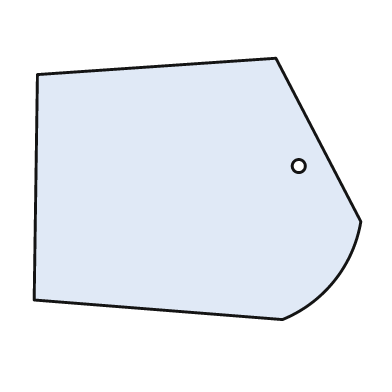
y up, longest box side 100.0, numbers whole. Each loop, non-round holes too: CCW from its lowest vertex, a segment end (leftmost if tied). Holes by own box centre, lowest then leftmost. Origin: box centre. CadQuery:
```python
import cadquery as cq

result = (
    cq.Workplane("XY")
    .moveTo(26.0, -40.0)
    .threePointArc((42.0, -28.0), (50.0, -10.0))
    .lineTo(24.0, 40.0)
    .lineTo(-49.0, 35.0)
    .lineTo(-50.0, -34.0)
    .close()
    .moveTo(31.0, 7.0)
    .circle(2.0)
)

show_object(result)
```